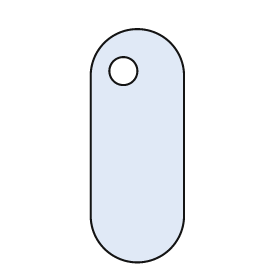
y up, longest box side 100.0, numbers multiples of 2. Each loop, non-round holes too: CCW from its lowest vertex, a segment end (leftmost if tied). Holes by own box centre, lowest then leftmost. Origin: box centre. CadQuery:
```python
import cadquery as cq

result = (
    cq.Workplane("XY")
    .moveTo(-20.0, -30.0)
    .threePointArc((0.0, -50.0), (20.0, -30.0))
    .lineTo(20.0, 30.0)
    .threePointArc((0.0, 50.0), (-20.0, 30.0))
    .close()
    .moveTo(-6.0, 32.0)
    .circle(6.0)
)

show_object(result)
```